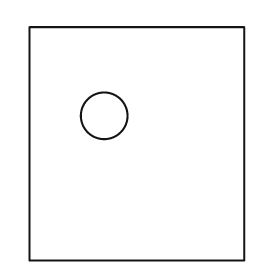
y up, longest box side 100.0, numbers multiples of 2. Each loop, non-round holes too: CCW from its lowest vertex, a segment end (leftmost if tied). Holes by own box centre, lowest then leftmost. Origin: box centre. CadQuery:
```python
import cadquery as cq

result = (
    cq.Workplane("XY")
    .moveTo(-46.0, -50.0)
    .lineTo(46.0, -50.0)
    .lineTo(46.0, 50.0)
    .lineTo(-46.0, 50.0)
    .close()
    .moveTo(-14.0, 12.0)
    .circle(10.0)
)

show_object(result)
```